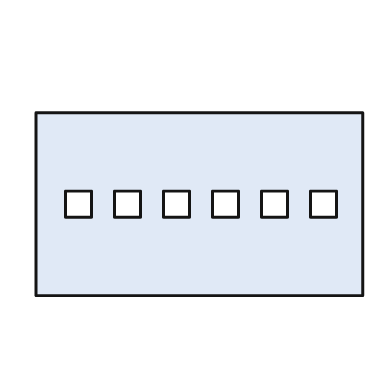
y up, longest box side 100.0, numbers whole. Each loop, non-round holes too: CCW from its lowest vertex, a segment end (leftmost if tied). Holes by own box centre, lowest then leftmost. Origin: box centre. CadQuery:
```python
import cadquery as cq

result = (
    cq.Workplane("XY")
    .moveTo(-50.0, -28.0)
    .lineTo(50.0, -28.0)
    .lineTo(50.0, 28.0)
    .lineTo(-50.0, 28.0)
    .close()
    .moveTo(-41.0, -4.0)
    .lineTo(-33.0, -4.0)
    .lineTo(-33.0, 4.0)
    .lineTo(-41.0, 4.0)
    .close()
    .moveTo(-26.0, -4.0)
    .lineTo(-18.0, -4.0)
    .lineTo(-18.0, 4.0)
    .lineTo(-26.0, 4.0)
    .close()
    .moveTo(-11.0, -4.0)
    .lineTo(-3.0, -4.0)
    .lineTo(-3.0, 4.0)
    .lineTo(-11.0, 4.0)
    .close()
    .moveTo(4.0, -4.0)
    .lineTo(12.0, -4.0)
    .lineTo(12.0, 4.0)
    .lineTo(4.0, 4.0)
    .close()
    .moveTo(19.0, -4.0)
    .lineTo(27.0, -4.0)
    .lineTo(27.0, 4.0)
    .lineTo(19.0, 4.0)
    .close()
    .moveTo(34.0, -4.0)
    .lineTo(42.0, -4.0)
    .lineTo(42.0, 4.0)
    .lineTo(34.0, 4.0)
    .close()
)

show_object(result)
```